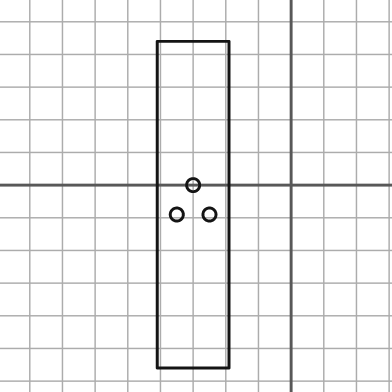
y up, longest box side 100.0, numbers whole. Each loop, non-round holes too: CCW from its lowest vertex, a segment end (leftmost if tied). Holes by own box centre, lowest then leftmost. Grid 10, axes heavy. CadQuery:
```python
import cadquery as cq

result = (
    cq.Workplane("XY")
    .moveTo(-41.0, -56.0)
    .lineTo(-19.0, -56.0)
    .lineTo(-19.0, 44.0)
    .lineTo(-41.0, 44.0)
    .close()
    .moveTo(-35.0, -9.0)
    .circle(2.0)
    .moveTo(-25.0, -9.0)
    .circle(2.0)
    .moveTo(-30.0, 0.0)
    .circle(2.0)
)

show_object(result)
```